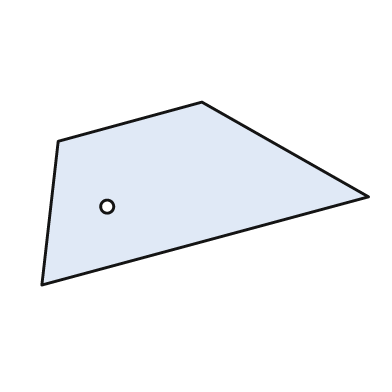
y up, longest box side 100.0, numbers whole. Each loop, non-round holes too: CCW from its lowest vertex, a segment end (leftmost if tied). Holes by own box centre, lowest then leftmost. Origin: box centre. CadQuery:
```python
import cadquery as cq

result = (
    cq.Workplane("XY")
    .moveTo(-50.0, -28.0)
    .lineTo(50.0, -1.0)
    .lineTo(-1.0, 28.0)
    .lineTo(-45.0, 16.0)
    .close()
    .moveTo(-30.0, -4.0)
    .circle(2.0)
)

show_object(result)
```